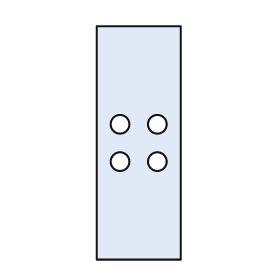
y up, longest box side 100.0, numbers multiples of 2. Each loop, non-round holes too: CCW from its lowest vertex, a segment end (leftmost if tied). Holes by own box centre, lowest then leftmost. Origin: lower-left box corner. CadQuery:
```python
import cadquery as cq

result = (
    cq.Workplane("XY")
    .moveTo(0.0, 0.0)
    .lineTo(36.0, 0.0)
    .lineTo(36.0, 100.0)
    .lineTo(0.0, 100.0)
    .close()
    .moveTo(10.0, 42.0)
    .circle(4.0)
    .moveTo(26.0, 42.0)
    .circle(4.0)
    .moveTo(10.0, 58.0)
    .circle(4.0)
    .moveTo(26.0, 58.0)
    .circle(4.0)
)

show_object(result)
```